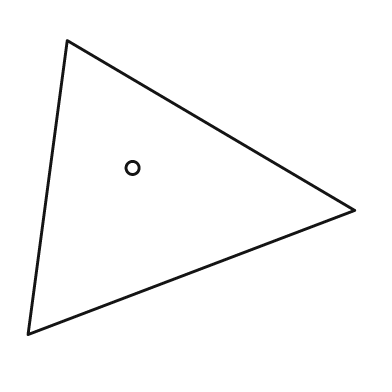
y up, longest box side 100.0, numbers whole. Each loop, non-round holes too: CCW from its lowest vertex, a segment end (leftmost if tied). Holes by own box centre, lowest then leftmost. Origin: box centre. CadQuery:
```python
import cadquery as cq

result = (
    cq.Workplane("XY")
    .moveTo(-50.0, -45.0)
    .lineTo(50.0, -7.0)
    .lineTo(-38.0, 45.0)
    .close()
    .moveTo(-18.0, 6.0)
    .circle(2.0)
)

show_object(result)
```